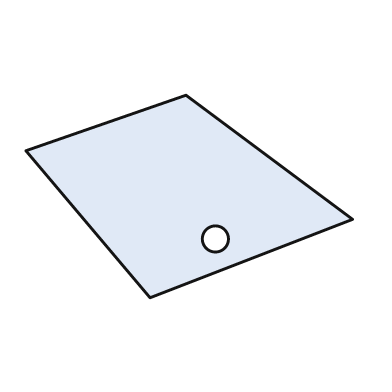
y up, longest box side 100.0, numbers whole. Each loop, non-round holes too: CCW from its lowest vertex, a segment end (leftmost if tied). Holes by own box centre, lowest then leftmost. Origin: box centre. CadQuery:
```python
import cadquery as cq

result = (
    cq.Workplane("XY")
    .moveTo(-12.0, -31.0)
    .lineTo(50.0, -7.0)
    .lineTo(-1.0, 31.0)
    .lineTo(-50.0, 14.0)
    .close()
    .moveTo(8.0, -13.0)
    .circle(4.0)
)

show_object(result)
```